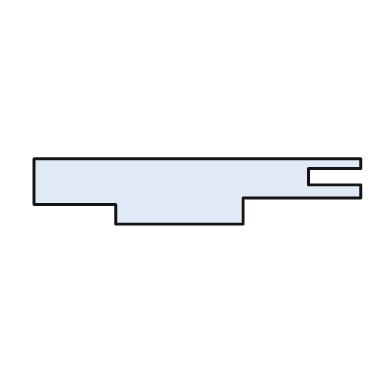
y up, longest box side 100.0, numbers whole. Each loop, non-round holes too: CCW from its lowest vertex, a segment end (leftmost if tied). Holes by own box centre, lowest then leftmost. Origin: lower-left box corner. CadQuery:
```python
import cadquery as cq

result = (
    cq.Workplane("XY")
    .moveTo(25.0, 0.0)
    .lineTo(64.0, 0.0)
    .lineTo(64.0, 8.0)
    .lineTo(100.0, 8.0)
    .lineTo(100.0, 12.0)
    .lineTo(84.0, 12.0)
    .lineTo(84.0, 17.0)
    .lineTo(100.0, 17.0)
    .lineTo(100.0, 20.0)
    .lineTo(0.0, 20.0)
    .lineTo(0.0, 6.0)
    .lineTo(25.0, 6.0)
    .close()
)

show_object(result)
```